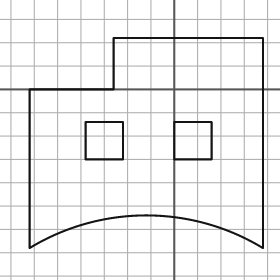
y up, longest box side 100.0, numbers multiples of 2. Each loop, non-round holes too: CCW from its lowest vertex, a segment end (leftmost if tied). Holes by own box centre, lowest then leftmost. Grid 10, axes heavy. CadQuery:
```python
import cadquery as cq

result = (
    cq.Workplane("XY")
    .moveTo(-62.0, -68.0)
    .threePointArc((-12.0, -54.0), (38.0, -68.0))
    .lineTo(38.0, 22.0)
    .lineTo(-26.0, 22.0)
    .lineTo(-26.0, 0.0)
    .lineTo(-62.0, 0.0)
    .close()
    .moveTo(-38.0, -30.0)
    .lineTo(-22.0, -30.0)
    .lineTo(-22.0, -14.0)
    .lineTo(-38.0, -14.0)
    .close()
    .moveTo(0.0, -30.0)
    .lineTo(16.0, -30.0)
    .lineTo(16.0, -14.0)
    .lineTo(0.0, -14.0)
    .close()
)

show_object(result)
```